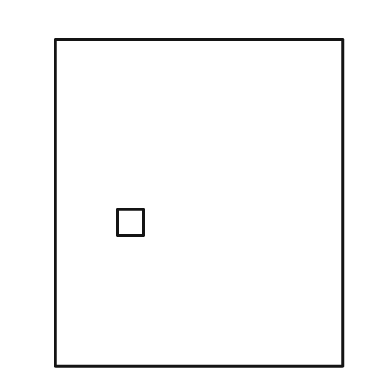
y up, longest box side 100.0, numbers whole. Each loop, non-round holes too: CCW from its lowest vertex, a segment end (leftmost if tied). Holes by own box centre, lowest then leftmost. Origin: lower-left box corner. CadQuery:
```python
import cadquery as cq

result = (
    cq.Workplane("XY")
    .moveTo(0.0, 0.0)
    .lineTo(88.0, 0.0)
    .lineTo(88.0, 100.0)
    .lineTo(0.0, 100.0)
    .close()
    .moveTo(19.0, 40.0)
    .lineTo(27.0, 40.0)
    .lineTo(27.0, 48.0)
    .lineTo(19.0, 48.0)
    .close()
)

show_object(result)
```